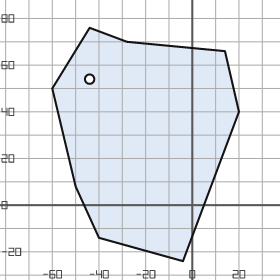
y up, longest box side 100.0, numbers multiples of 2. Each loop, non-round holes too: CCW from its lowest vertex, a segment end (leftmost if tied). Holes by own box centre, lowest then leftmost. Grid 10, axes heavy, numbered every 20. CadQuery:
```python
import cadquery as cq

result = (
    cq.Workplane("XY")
    .moveTo(-4.0, -24.0)
    .lineTo(20.0, 40.0)
    .lineTo(14.0, 66.0)
    .lineTo(-28.0, 70.0)
    .lineTo(-44.0, 76.0)
    .lineTo(-60.0, 50.0)
    .lineTo(-50.0, 8.0)
    .lineTo(-40.0, -14.0)
    .close()
    .moveTo(-44.0, 54.0)
    .circle(2.0)
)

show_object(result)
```